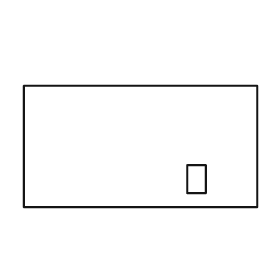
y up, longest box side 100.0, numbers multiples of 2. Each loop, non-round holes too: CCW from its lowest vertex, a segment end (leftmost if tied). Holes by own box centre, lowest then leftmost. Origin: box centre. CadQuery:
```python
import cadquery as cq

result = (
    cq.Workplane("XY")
    .moveTo(-50.0, -26.0)
    .lineTo(50.0, -26.0)
    .lineTo(50.0, 26.0)
    .lineTo(-50.0, 26.0)
    .close()
    .moveTo(20.0, -20.0)
    .lineTo(28.0, -20.0)
    .lineTo(28.0, -8.0)
    .lineTo(20.0, -8.0)
    .close()
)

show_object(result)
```